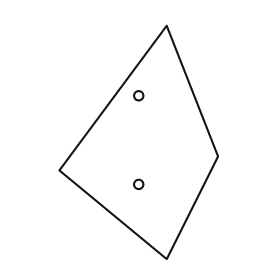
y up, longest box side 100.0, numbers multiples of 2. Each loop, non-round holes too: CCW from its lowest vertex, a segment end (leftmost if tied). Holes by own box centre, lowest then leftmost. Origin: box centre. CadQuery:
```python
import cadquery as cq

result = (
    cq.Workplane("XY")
    .moveTo(12.0, -50.0)
    .lineTo(34.0, -6.0)
    .lineTo(12.0, 50.0)
    .lineTo(-34.0, -12.0)
    .close()
    .moveTo(0.0, -18.0)
    .circle(2.0)
    .moveTo(0.0, 20.0)
    .circle(2.0)
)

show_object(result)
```